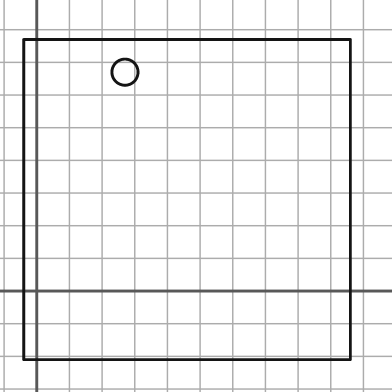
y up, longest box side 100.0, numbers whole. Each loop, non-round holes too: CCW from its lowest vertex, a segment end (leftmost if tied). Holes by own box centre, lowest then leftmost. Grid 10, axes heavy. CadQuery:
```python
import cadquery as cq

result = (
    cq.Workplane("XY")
    .moveTo(-4.0, -21.0)
    .lineTo(96.0, -21.0)
    .lineTo(96.0, 77.0)
    .lineTo(-4.0, 77.0)
    .close()
    .moveTo(27.0, 67.0)
    .circle(4.0)
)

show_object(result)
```